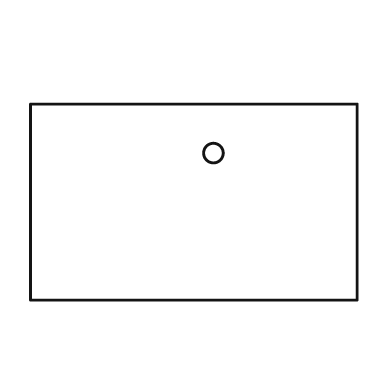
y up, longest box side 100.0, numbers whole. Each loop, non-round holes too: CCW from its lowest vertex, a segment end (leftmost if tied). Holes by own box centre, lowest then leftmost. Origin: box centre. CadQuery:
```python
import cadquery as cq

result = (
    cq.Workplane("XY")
    .moveTo(-50.0, -30.0)
    .lineTo(50.0, -30.0)
    .lineTo(50.0, 30.0)
    .lineTo(-50.0, 30.0)
    .close()
    .moveTo(6.0, 15.0)
    .circle(3.0)
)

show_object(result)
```